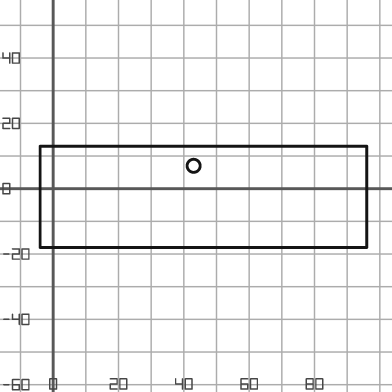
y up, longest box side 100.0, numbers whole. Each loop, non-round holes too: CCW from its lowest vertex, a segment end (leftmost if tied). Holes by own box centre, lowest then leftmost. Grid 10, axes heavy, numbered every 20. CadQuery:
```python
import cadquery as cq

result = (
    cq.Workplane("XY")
    .moveTo(-4.0, -18.0)
    .lineTo(96.0, -18.0)
    .lineTo(96.0, 13.0)
    .lineTo(-4.0, 13.0)
    .close()
    .moveTo(43.0, 7.0)
    .circle(2.0)
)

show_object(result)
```